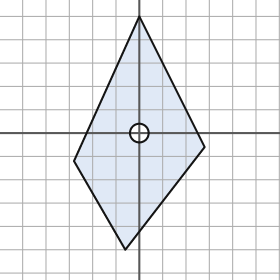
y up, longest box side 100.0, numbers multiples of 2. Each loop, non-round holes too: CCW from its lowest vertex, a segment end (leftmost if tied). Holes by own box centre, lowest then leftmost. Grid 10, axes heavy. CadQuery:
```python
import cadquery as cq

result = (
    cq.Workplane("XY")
    .moveTo(-6.0, -50.0)
    .lineTo(28.0, -6.0)
    .lineTo(0.0, 50.0)
    .lineTo(-28.0, -12.0)
    .close()
    .moveTo(0.0, 0.0)
    .circle(4.0)
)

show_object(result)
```